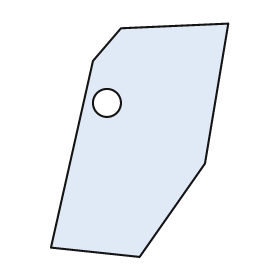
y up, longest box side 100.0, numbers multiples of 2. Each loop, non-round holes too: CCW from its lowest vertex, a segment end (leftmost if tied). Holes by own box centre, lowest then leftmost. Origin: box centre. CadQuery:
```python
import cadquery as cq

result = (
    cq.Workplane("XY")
    .moveTo(0.0, -50.0)
    .lineTo(28.0, -10.0)
    .lineTo(38.0, 50.0)
    .lineTo(-8.0, 48.0)
    .lineTo(-20.0, 34.0)
    .lineTo(-38.0, -46.0)
    .close()
    .moveTo(-14.0, 16.0)
    .circle(6.0)
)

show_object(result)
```